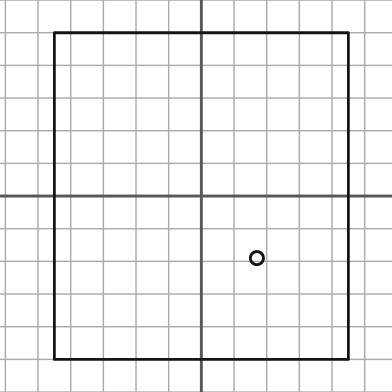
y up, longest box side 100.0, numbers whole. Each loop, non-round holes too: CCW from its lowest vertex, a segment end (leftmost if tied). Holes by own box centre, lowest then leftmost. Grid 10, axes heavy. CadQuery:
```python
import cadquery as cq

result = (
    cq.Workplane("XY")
    .moveTo(-45.0, -50.0)
    .lineTo(45.0, -50.0)
    .lineTo(45.0, 50.0)
    .lineTo(-45.0, 50.0)
    .close()
    .moveTo(17.0, -19.0)
    .circle(2.0)
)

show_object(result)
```